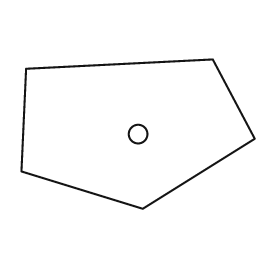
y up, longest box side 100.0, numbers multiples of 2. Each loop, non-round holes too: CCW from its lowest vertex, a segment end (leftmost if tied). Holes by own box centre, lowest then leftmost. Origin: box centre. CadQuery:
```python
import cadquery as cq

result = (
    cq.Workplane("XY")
    .moveTo(2.0, -32.0)
    .lineTo(50.0, -2.0)
    .lineTo(32.0, 32.0)
    .lineTo(-48.0, 28.0)
    .lineTo(-50.0, -16.0)
    .close()
    .moveTo(0.0, 0.0)
    .circle(4.0)
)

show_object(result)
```